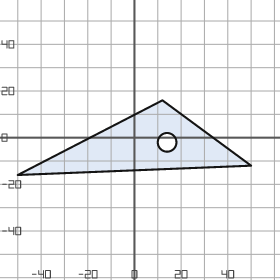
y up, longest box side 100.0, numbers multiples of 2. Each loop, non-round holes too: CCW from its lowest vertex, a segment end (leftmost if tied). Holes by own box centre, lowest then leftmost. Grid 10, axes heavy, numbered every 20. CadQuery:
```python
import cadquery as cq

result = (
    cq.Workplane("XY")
    .moveTo(-50.0, -16.0)
    .lineTo(50.0, -12.0)
    .lineTo(12.0, 16.0)
    .close()
    .moveTo(14.0, -2.0)
    .circle(4.0)
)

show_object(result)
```